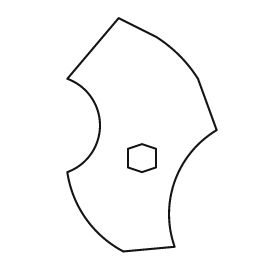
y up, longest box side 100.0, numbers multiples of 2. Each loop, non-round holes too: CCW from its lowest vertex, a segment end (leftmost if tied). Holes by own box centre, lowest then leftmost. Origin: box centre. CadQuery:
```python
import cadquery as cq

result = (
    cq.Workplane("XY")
    .moveTo(-8.0, -50.0)
    .lineTo(14.0, -48.0)
    .threePointArc((14.0, -20.0), (32.0, 2.0))
    .lineTo(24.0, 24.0)
    .threePointArc((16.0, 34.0), (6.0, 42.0))
    .lineTo(-10.0, 50.0)
    .lineTo(-32.0, 24.0)
    .threePointArc((-18.0, 4.0), (-32.0, -16.0))
    .threePointArc((-24.0, -36.0), (-8.0, -50.0))
    .close()
    .moveTo(0.0, -16.0)
    .lineTo(6.0, -14.0)
    .lineTo(6.0, -6.0)
    .lineTo(0.0, -4.0)
    .lineTo(-6.0, -6.0)
    .lineTo(-6.0, -14.0)
    .close()
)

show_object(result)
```